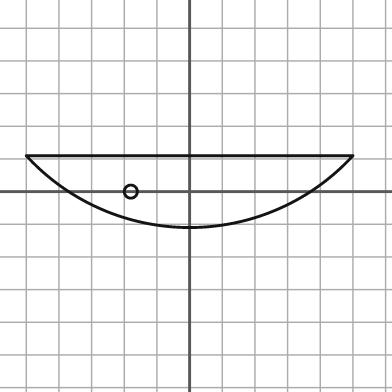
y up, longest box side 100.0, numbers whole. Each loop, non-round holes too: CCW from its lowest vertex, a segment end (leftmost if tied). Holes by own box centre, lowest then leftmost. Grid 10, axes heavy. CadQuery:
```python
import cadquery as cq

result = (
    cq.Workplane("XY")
    .moveTo(-50.0, 11.0)
    .threePointArc((0.0, -11.0), (50.0, 11.0))
    .close()
    .moveTo(-18.0, 0.0)
    .circle(2.0)
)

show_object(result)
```